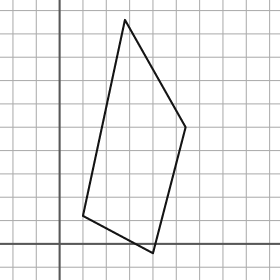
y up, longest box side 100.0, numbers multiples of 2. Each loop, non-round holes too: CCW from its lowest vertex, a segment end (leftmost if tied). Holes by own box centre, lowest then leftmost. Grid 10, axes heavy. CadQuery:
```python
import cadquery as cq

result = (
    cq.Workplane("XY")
    .moveTo(40.0, -4.0)
    .lineTo(54.0, 50.0)
    .lineTo(28.0, 96.0)
    .lineTo(10.0, 12.0)
    .close()
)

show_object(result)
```